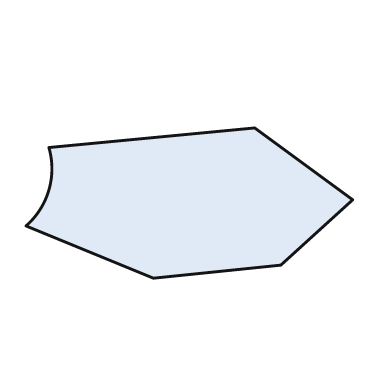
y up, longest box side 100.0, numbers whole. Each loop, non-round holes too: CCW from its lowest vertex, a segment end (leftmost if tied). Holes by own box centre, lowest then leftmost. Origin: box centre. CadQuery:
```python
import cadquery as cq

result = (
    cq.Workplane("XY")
    .moveTo(-11.0, -23.0)
    .lineTo(28.0, -19.0)
    .lineTo(50.0, 1.0)
    .lineTo(20.0, 23.0)
    .lineTo(-43.0, 17.0)
    .threePointArc((-43.0, 4.0), (-50.0, -7.0))
    .close()
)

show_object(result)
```